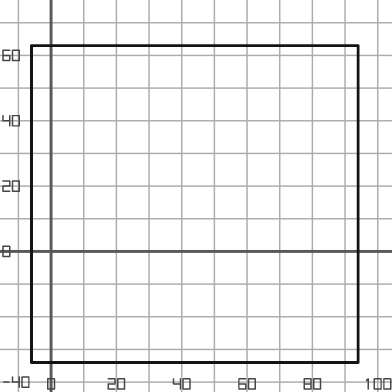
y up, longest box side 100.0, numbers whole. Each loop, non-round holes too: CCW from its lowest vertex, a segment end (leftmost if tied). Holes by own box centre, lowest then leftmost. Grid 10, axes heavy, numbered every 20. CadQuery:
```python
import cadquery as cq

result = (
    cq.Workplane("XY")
    .moveTo(-6.0, -34.0)
    .lineTo(94.0, -34.0)
    .lineTo(94.0, 63.0)
    .lineTo(-6.0, 63.0)
    .close()
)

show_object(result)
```